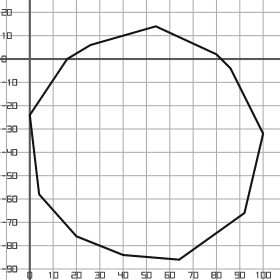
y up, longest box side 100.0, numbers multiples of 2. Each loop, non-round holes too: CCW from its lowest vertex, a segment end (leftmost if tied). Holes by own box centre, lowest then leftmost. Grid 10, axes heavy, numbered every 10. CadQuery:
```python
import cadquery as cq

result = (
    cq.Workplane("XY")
    .moveTo(64.0, -86.0)
    .lineTo(92.0, -66.0)
    .lineTo(100.0, -32.0)
    .lineTo(86.0, -4.0)
    .lineTo(80.0, 2.0)
    .lineTo(54.0, 14.0)
    .lineTo(26.0, 6.0)
    .lineTo(16.0, 0.0)
    .lineTo(0.0, -24.0)
    .lineTo(4.0, -58.0)
    .lineTo(20.0, -76.0)
    .lineTo(40.0, -84.0)
    .close()
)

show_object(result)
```